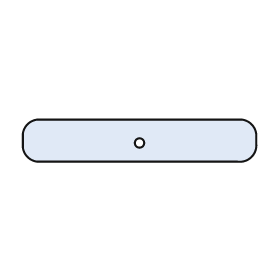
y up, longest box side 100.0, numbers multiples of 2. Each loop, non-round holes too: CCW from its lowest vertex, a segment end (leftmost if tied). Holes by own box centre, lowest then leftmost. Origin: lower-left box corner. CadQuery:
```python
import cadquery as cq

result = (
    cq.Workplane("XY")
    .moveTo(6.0, 0.0)
    .lineTo(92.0, 0.0)
    .threePointArc((98.0, 2.0), (100.0, 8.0))
    .lineTo(100.0, 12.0)
    .threePointArc((98.0, 16.0), (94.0, 18.0))
    .lineTo(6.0, 18.0)
    .threePointArc((2.0, 16.0), (0.0, 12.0))
    .lineTo(0.0, 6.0)
    .threePointArc((2.0, 2.0), (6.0, 0.0))
    .close()
    .moveTo(50.0, 8.0)
    .circle(2.0)
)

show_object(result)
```